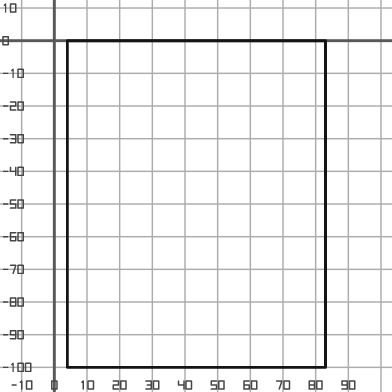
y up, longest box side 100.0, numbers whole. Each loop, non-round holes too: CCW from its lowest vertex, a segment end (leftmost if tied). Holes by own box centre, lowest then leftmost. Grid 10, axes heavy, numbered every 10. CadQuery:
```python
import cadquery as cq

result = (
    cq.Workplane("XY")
    .moveTo(4.0, -100.0)
    .lineTo(83.0, -100.0)
    .lineTo(83.0, 0.0)
    .lineTo(4.0, 0.0)
    .close()
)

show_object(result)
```